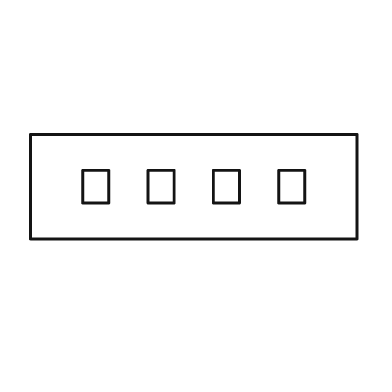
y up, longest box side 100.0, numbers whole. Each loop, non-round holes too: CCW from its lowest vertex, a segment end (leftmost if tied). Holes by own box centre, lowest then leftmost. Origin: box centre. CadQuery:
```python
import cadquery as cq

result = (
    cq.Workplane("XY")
    .moveTo(-50.0, -16.0)
    .lineTo(50.0, -16.0)
    .lineTo(50.0, 16.0)
    .lineTo(-50.0, 16.0)
    .close()
    .moveTo(-34.0, -5.0)
    .lineTo(-26.0, -5.0)
    .lineTo(-26.0, 5.0)
    .lineTo(-34.0, 5.0)
    .close()
    .moveTo(-14.0, -5.0)
    .lineTo(-6.0, -5.0)
    .lineTo(-6.0, 5.0)
    .lineTo(-14.0, 5.0)
    .close()
    .moveTo(6.0, -5.0)
    .lineTo(14.0, -5.0)
    .lineTo(14.0, 5.0)
    .lineTo(6.0, 5.0)
    .close()
    .moveTo(26.0, -5.0)
    .lineTo(34.0, -5.0)
    .lineTo(34.0, 5.0)
    .lineTo(26.0, 5.0)
    .close()
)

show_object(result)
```